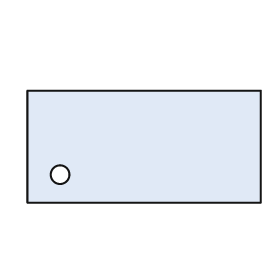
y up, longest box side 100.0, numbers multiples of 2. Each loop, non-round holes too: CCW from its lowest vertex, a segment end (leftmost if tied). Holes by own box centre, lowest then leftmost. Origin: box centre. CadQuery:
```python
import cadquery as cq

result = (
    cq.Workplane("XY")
    .moveTo(-50.0, -24.0)
    .lineTo(50.0, -24.0)
    .lineTo(50.0, 24.0)
    .lineTo(-50.0, 24.0)
    .close()
    .moveTo(-36.0, -12.0)
    .circle(4.0)
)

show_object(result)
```